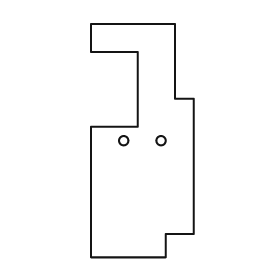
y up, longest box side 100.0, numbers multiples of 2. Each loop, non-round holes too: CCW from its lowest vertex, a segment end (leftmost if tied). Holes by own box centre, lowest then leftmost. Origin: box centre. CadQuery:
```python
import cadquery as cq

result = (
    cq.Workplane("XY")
    .moveTo(-22.0, -50.0)
    .lineTo(10.0, -50.0)
    .lineTo(10.0, -40.0)
    .lineTo(22.0, -40.0)
    .lineTo(22.0, 18.0)
    .lineTo(14.0, 18.0)
    .lineTo(14.0, 50.0)
    .lineTo(-22.0, 50.0)
    .lineTo(-22.0, 38.0)
    .lineTo(-2.0, 38.0)
    .lineTo(-2.0, 6.0)
    .lineTo(-22.0, 6.0)
    .close()
    .moveTo(-8.0, 0.0)
    .circle(2.0)
    .moveTo(8.0, 0.0)
    .circle(2.0)
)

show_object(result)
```